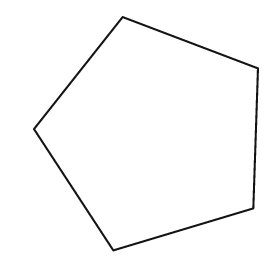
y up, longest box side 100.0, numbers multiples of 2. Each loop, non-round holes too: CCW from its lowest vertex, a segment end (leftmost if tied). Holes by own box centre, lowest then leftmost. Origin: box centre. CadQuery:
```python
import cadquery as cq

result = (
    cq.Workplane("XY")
    .moveTo(-14.0, -50.0)
    .lineTo(46.0, -32.0)
    .lineTo(48.0, 28.0)
    .lineTo(-10.0, 50.0)
    .lineTo(-48.0, 2.0)
    .close()
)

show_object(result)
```